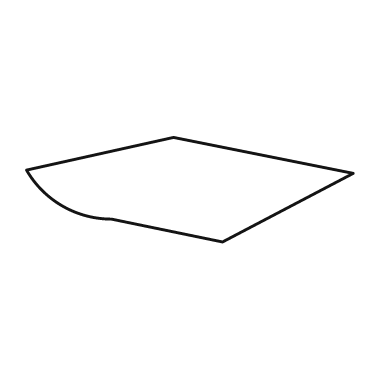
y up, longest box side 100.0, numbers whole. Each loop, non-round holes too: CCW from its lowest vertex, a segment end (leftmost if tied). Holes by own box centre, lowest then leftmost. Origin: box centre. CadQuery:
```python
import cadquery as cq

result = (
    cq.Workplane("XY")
    .moveTo(10.0, -16.0)
    .lineTo(50.0, 5.0)
    .lineTo(-5.0, 16.0)
    .lineTo(-50.0, 6.0)
    .threePointArc((-39.0, -5.0), (-24.0, -9.0))
    .close()
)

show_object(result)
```